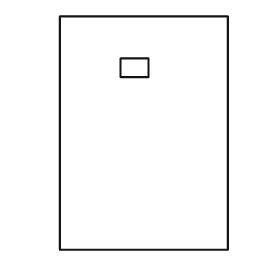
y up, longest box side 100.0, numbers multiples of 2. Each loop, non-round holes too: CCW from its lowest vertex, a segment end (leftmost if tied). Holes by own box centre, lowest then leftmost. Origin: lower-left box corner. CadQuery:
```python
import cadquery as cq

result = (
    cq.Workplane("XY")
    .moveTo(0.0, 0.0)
    .lineTo(72.0, 0.0)
    .lineTo(72.0, 100.0)
    .lineTo(0.0, 100.0)
    .close()
    .moveTo(26.0, 74.0)
    .lineTo(38.0, 74.0)
    .lineTo(38.0, 82.0)
    .lineTo(26.0, 82.0)
    .close()
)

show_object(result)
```